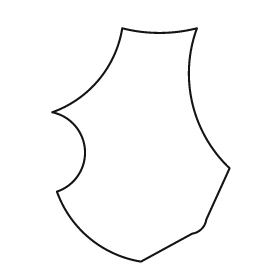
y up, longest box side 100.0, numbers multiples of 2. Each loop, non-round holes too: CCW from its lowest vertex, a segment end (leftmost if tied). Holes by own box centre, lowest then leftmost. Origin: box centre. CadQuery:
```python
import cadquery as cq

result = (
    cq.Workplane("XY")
    .moveTo(0.0, -50.0)
    .lineTo(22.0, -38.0)
    .threePointArc((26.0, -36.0), (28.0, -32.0))
    .lineTo(38.0, -10.0)
    .threePointArc((22.0, 18.0), (24.0, 50.0))
    .threePointArc((8.0, 48.0), (-8.0, 50.0))
    .threePointArc((-18.0, 28.0), (-38.0, 14.0))
    .threePointArc((-24.0, -2.0), (-36.0, -20.0))
    .threePointArc((-22.0, -40.0), (0.0, -50.0))
    .close()
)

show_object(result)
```